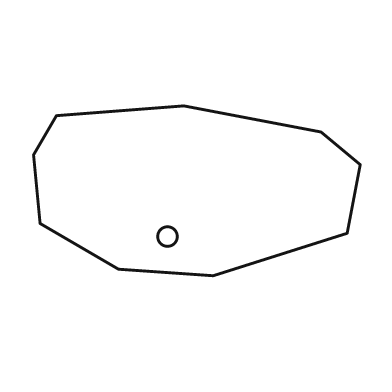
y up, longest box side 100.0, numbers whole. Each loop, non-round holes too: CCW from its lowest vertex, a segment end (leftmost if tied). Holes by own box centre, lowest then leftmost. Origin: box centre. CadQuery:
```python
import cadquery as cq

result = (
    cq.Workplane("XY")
    .moveTo(5.0, -26.0)
    .lineTo(46.0, -13.0)
    .lineTo(50.0, 8.0)
    .lineTo(38.0, 18.0)
    .lineTo(-4.0, 26.0)
    .lineTo(-43.0, 23.0)
    .lineTo(-50.0, 11.0)
    .lineTo(-48.0, -10.0)
    .lineTo(-24.0, -24.0)
    .close()
    .moveTo(-9.0, -14.0)
    .circle(3.0)
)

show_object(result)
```